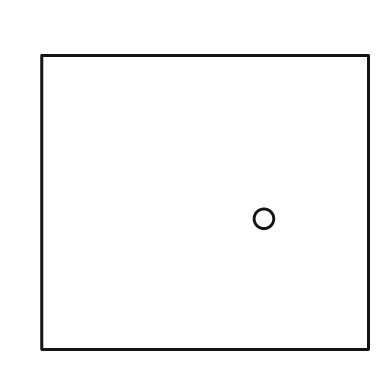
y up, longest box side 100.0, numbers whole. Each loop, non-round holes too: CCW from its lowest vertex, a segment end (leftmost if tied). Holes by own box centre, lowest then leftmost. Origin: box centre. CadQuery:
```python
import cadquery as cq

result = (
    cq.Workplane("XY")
    .moveTo(-50.0, -45.0)
    .lineTo(50.0, -45.0)
    .lineTo(50.0, 45.0)
    .lineTo(-50.0, 45.0)
    .close()
    .moveTo(18.0, -5.0)
    .circle(3.0)
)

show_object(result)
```